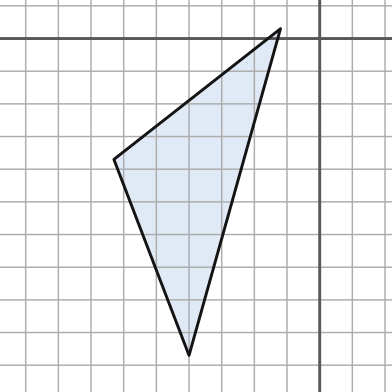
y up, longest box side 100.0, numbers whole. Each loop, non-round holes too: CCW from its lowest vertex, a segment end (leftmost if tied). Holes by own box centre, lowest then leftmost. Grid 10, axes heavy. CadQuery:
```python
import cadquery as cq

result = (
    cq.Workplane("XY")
    .moveTo(-40.0, -97.0)
    .lineTo(-12.0, 3.0)
    .lineTo(-63.0, -37.0)
    .close()
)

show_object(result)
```